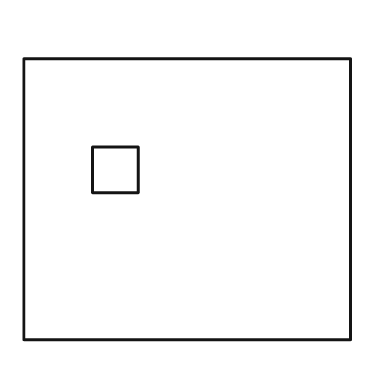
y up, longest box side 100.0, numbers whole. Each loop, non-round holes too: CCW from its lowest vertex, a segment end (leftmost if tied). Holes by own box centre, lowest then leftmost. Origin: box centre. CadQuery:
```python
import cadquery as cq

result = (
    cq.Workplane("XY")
    .moveTo(-50.0, -43.0)
    .lineTo(50.0, -43.0)
    .lineTo(50.0, 43.0)
    .lineTo(-50.0, 43.0)
    .close()
    .moveTo(-29.0, 2.0)
    .lineTo(-15.0, 2.0)
    .lineTo(-15.0, 16.0)
    .lineTo(-29.0, 16.0)
    .close()
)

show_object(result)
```